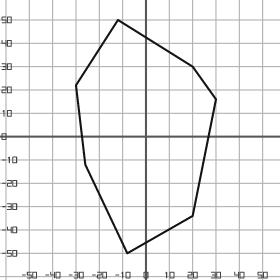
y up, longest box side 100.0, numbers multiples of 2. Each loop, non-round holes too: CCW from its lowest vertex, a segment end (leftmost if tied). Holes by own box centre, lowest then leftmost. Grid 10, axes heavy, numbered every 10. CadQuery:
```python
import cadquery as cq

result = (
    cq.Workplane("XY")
    .moveTo(-8.0, -50.0)
    .lineTo(20.0, -34.0)
    .lineTo(30.0, 16.0)
    .lineTo(20.0, 30.0)
    .lineTo(-12.0, 50.0)
    .lineTo(-30.0, 22.0)
    .lineTo(-26.0, -12.0)
    .close()
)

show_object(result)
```